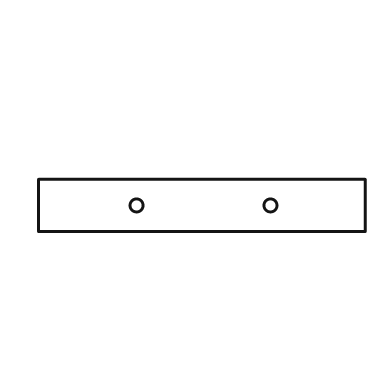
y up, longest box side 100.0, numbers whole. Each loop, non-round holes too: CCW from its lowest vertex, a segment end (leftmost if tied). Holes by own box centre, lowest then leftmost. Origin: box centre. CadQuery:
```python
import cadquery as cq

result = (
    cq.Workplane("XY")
    .moveTo(-50.0, -8.0)
    .lineTo(50.0, -8.0)
    .lineTo(50.0, 8.0)
    .lineTo(-50.0, 8.0)
    .close()
    .moveTo(-20.0, 0.0)
    .circle(2.0)
    .moveTo(21.0, 0.0)
    .circle(2.0)
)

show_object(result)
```